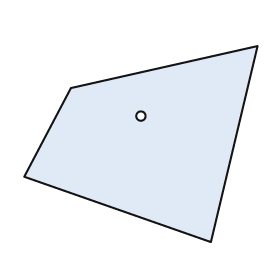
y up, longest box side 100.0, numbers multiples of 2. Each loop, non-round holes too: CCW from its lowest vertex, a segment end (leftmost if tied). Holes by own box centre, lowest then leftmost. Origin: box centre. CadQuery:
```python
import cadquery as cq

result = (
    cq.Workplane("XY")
    .moveTo(30.0, -42.0)
    .lineTo(50.0, 42.0)
    .lineTo(-30.0, 24.0)
    .lineTo(-50.0, -14.0)
    .close()
    .moveTo(0.0, 12.0)
    .circle(2.0)
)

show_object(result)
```